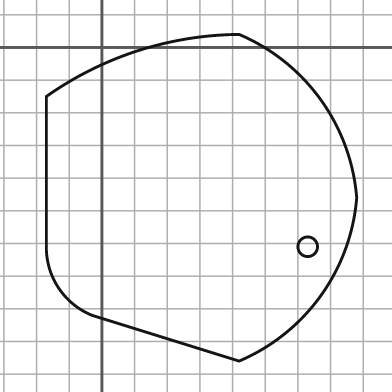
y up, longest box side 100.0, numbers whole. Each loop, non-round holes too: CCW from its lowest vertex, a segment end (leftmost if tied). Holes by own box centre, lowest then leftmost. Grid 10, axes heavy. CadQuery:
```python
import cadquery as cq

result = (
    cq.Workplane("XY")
    .moveTo(42.0, -96.0)
    .threePointArc((67.0, -76.0), (78.0, -46.0))
    .threePointArc((67.0, -16.0), (42.0, 4.0))
    .threePointArc((11.0, -1.0), (-17.0, -15.0))
    .lineTo(-17.0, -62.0)
    .threePointArc((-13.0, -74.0), (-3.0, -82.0))
    .close()
    .moveTo(63.0, -61.0)
    .circle(3.0)
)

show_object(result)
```